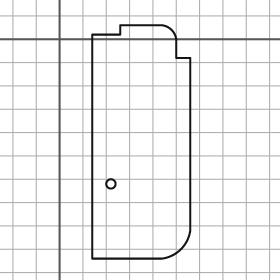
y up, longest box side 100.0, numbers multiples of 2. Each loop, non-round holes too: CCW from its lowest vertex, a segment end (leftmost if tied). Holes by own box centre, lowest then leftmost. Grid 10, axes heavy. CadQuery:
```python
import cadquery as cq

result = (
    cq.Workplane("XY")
    .moveTo(14.0, -94.0)
    .lineTo(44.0, -94.0)
    .threePointArc((52.0, -90.0), (56.0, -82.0))
    .lineTo(56.0, -8.0)
    .lineTo(50.0, -8.0)
    .lineTo(50.0, 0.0)
    .threePointArc((48.0, 4.0), (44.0, 6.0))
    .lineTo(26.0, 6.0)
    .lineTo(26.0, 2.0)
    .lineTo(14.0, 2.0)
    .close()
    .moveTo(22.0, -62.0)
    .circle(2.0)
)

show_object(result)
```